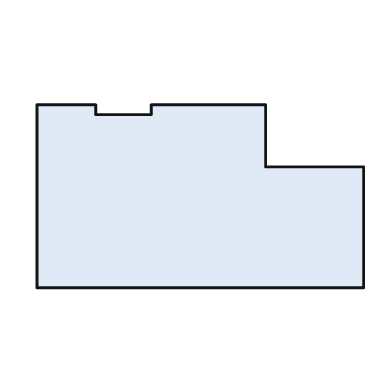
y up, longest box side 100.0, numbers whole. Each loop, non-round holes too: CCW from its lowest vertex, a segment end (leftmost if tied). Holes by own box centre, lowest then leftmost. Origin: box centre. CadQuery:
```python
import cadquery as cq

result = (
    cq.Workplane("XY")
    .moveTo(-50.0, -28.0)
    .lineTo(50.0, -28.0)
    .lineTo(50.0, 9.0)
    .lineTo(20.0, 9.0)
    .lineTo(20.0, 28.0)
    .lineTo(-15.0, 28.0)
    .lineTo(-15.0, 25.0)
    .lineTo(-32.0, 25.0)
    .lineTo(-32.0, 28.0)
    .lineTo(-50.0, 28.0)
    .close()
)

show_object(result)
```